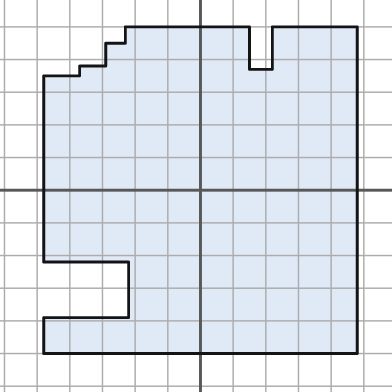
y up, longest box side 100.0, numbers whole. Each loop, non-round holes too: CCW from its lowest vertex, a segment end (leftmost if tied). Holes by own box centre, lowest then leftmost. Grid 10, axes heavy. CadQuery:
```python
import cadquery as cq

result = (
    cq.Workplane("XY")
    .moveTo(-48.0, -50.0)
    .lineTo(48.0, -50.0)
    .lineTo(48.0, 50.0)
    .lineTo(22.0, 50.0)
    .lineTo(22.0, 37.0)
    .lineTo(15.0, 37.0)
    .lineTo(15.0, 50.0)
    .lineTo(-23.0, 50.0)
    .lineTo(-23.0, 45.0)
    .lineTo(-29.0, 45.0)
    .lineTo(-29.0, 38.0)
    .lineTo(-37.0, 38.0)
    .lineTo(-37.0, 35.0)
    .lineTo(-48.0, 35.0)
    .lineTo(-48.0, -22.0)
    .lineTo(-22.0, -22.0)
    .lineTo(-22.0, -39.0)
    .lineTo(-48.0, -39.0)
    .close()
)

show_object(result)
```